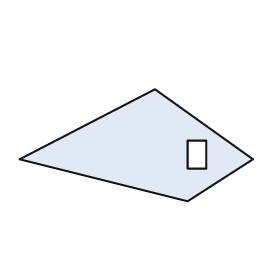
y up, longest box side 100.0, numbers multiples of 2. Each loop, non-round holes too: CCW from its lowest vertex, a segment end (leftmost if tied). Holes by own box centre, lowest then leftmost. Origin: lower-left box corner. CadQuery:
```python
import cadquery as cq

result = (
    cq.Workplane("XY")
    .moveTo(72.0, 0.0)
    .lineTo(100.0, 18.0)
    .lineTo(58.0, 48.0)
    .lineTo(0.0, 18.0)
    .close()
    .moveTo(72.0, 14.0)
    .lineTo(80.0, 14.0)
    .lineTo(80.0, 26.0)
    .lineTo(72.0, 26.0)
    .close()
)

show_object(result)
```